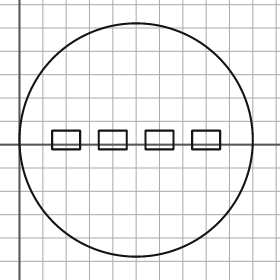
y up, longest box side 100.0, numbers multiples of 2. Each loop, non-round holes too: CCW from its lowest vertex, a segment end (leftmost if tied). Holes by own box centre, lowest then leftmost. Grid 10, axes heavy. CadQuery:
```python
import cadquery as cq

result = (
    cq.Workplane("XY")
    .moveTo(50.0, 2.0)
    .circle(50.0)
    .moveTo(14.0, -2.0)
    .lineTo(26.0, -2.0)
    .lineTo(26.0, 6.0)
    .lineTo(14.0, 6.0)
    .close()
    .moveTo(34.0, -2.0)
    .lineTo(46.0, -2.0)
    .lineTo(46.0, 6.0)
    .lineTo(34.0, 6.0)
    .close()
    .moveTo(54.0, -2.0)
    .lineTo(66.0, -2.0)
    .lineTo(66.0, 6.0)
    .lineTo(54.0, 6.0)
    .close()
    .moveTo(74.0, -2.0)
    .lineTo(86.0, -2.0)
    .lineTo(86.0, 6.0)
    .lineTo(74.0, 6.0)
    .close()
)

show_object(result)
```